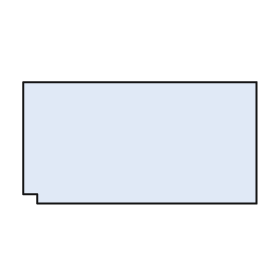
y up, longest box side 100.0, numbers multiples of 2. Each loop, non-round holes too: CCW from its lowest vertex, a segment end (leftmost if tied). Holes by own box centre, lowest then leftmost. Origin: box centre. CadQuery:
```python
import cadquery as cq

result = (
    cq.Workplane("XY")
    .moveTo(-44.0, -26.0)
    .lineTo(50.0, -26.0)
    .lineTo(50.0, 26.0)
    .lineTo(-50.0, 26.0)
    .lineTo(-50.0, -22.0)
    .lineTo(-44.0, -22.0)
    .close()
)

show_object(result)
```